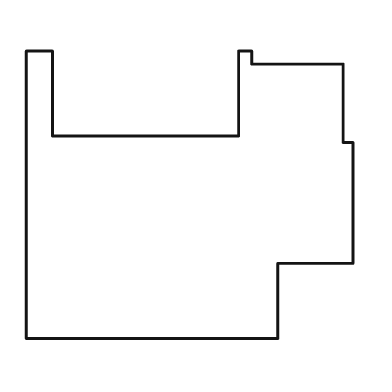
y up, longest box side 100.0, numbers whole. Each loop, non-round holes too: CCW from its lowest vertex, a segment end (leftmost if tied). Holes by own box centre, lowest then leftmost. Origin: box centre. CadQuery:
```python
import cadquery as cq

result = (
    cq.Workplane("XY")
    .moveTo(-50.0, -44.0)
    .lineTo(27.0, -44.0)
    .lineTo(27.0, -21.0)
    .lineTo(50.0, -21.0)
    .lineTo(50.0, 16.0)
    .lineTo(47.0, 16.0)
    .lineTo(47.0, 40.0)
    .lineTo(19.0, 40.0)
    .lineTo(19.0, 44.0)
    .lineTo(15.0, 44.0)
    .lineTo(15.0, 18.0)
    .lineTo(-42.0, 18.0)
    .lineTo(-42.0, 44.0)
    .lineTo(-50.0, 44.0)
    .close()
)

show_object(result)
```